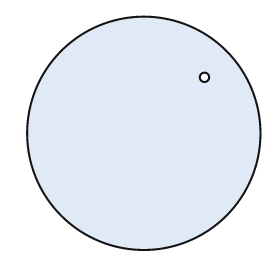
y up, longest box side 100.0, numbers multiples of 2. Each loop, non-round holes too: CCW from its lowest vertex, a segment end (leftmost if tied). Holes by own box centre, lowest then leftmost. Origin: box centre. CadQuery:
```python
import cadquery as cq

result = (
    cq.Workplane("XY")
    .moveTo(0.0, 0.0)
    .circle(50.0)
    .moveTo(26.0, 24.0)
    .circle(2.0)
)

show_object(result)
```